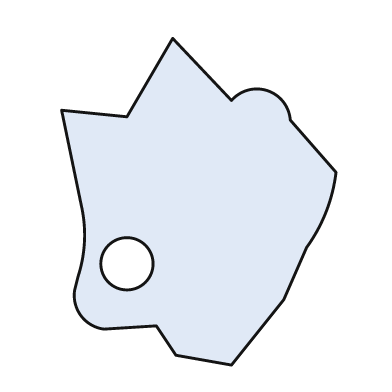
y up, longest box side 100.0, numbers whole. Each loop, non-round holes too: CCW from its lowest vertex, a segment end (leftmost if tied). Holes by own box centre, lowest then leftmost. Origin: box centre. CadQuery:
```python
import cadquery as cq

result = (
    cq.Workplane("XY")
    .moveTo(10.0, -50.0)
    .lineTo(26.0, -30.0)
    .lineTo(33.0, -14.0)
    .threePointArc((39.0, -3.0), (42.0, 9.0))
    .lineTo(28.0, 25.0)
    .threePointArc((21.0, 34.0), (10.0, 31.0))
    .lineTo(-8.0, 50.0)
    .lineTo(-22.0, 26.0)
    .lineTo(-42.0, 28.0)
    .lineTo(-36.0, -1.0)
    .threePointArc((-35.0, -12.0), (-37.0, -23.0))
    .lineTo(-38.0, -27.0)
    .threePointArc((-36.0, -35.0), (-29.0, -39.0))
    .lineTo(-13.0, -38.0)
    .lineTo(-7.0, -47.0)
    .close()
    .moveTo(-22.0, -19.0)
    .circle(8.0)
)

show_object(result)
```